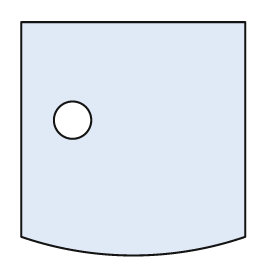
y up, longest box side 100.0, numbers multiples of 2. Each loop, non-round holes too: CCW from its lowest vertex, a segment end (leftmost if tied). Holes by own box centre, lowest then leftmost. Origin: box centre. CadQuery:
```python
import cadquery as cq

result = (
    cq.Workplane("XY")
    .moveTo(-48.0, -42.0)
    .threePointArc((0.0, -50.0), (48.0, -42.0))
    .lineTo(48.0, 50.0)
    .lineTo(-48.0, 50.0)
    .close()
    .moveTo(-26.0, 8.0)
    .circle(8.0)
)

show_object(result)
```